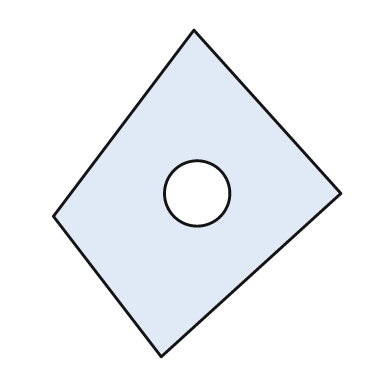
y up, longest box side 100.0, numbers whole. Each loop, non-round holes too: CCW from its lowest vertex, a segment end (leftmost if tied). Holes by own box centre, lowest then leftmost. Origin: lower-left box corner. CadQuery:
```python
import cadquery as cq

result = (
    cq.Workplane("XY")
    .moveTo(33.0, 0.0)
    .lineTo(88.0, 50.0)
    .lineTo(43.0, 100.0)
    .lineTo(0.0, 43.0)
    .close()
    .moveTo(44.0, 50.0)
    .circle(10.0)
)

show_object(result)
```